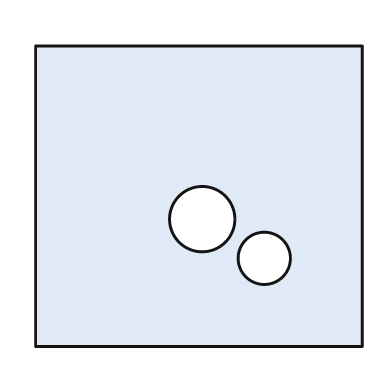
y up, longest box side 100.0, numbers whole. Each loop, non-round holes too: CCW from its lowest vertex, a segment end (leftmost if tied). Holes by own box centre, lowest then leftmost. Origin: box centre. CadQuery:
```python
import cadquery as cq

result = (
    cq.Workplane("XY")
    .moveTo(-50.0, -46.0)
    .lineTo(50.0, -46.0)
    .lineTo(50.0, 46.0)
    .lineTo(-50.0, 46.0)
    .close()
    .moveTo(20.0, -19.0)
    .circle(8.0)
    .moveTo(1.0, -7.0)
    .circle(10.0)
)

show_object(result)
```